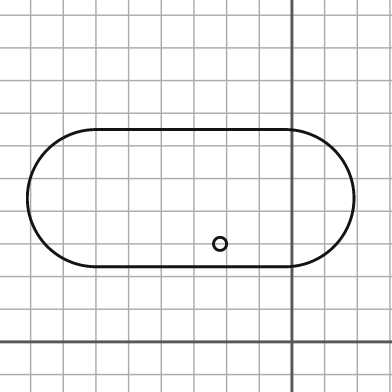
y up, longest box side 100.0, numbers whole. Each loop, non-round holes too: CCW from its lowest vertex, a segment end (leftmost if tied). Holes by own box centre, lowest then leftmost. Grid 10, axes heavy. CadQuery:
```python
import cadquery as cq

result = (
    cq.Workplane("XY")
    .moveTo(-60.0, 23.0)
    .lineTo(-2.0, 23.0)
    .threePointArc((19.0, 44.0), (-2.0, 65.0))
    .lineTo(-60.0, 65.0)
    .threePointArc((-81.0, 44.0), (-60.0, 23.0))
    .close()
    .moveTo(-22.0, 30.0)
    .circle(2.0)
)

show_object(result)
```